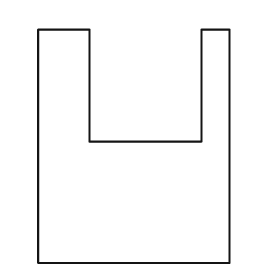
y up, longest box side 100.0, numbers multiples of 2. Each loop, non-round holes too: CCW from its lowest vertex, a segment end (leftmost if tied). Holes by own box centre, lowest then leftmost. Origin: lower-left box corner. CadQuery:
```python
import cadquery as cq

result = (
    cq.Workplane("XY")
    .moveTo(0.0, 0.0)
    .lineTo(82.0, 0.0)
    .lineTo(82.0, 100.0)
    .lineTo(70.0, 100.0)
    .lineTo(70.0, 52.0)
    .lineTo(22.0, 52.0)
    .lineTo(22.0, 100.0)
    .lineTo(0.0, 100.0)
    .close()
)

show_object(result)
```